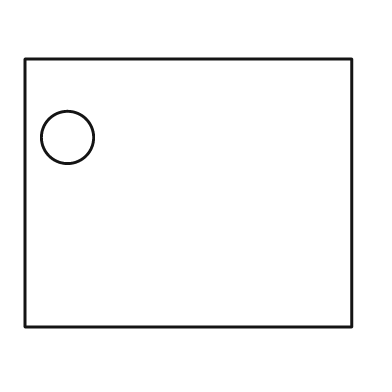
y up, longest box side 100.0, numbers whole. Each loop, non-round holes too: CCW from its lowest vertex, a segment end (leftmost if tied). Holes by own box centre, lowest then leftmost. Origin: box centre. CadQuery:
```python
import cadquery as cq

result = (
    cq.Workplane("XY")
    .moveTo(-50.0, -41.0)
    .lineTo(50.0, -41.0)
    .lineTo(50.0, 41.0)
    .lineTo(-50.0, 41.0)
    .close()
    .moveTo(-37.0, 17.0)
    .circle(8.0)
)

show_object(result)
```